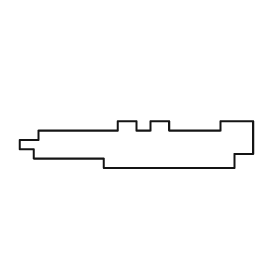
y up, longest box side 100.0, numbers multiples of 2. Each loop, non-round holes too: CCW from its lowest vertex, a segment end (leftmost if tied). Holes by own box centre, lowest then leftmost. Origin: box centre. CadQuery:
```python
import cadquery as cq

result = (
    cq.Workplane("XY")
    .moveTo(-14.0, -10.0)
    .lineTo(42.0, -10.0)
    .lineTo(42.0, -4.0)
    .lineTo(50.0, -4.0)
    .lineTo(50.0, 10.0)
    .lineTo(36.0, 10.0)
    .lineTo(36.0, 6.0)
    .lineTo(14.0, 6.0)
    .lineTo(14.0, 10.0)
    .lineTo(6.0, 10.0)
    .lineTo(6.0, 6.0)
    .lineTo(0.0, 6.0)
    .lineTo(0.0, 10.0)
    .lineTo(-8.0, 10.0)
    .lineTo(-8.0, 6.0)
    .lineTo(-42.0, 6.0)
    .lineTo(-42.0, 2.0)
    .lineTo(-50.0, 2.0)
    .lineTo(-50.0, -2.0)
    .lineTo(-44.0, -2.0)
    .lineTo(-44.0, -6.0)
    .lineTo(-14.0, -6.0)
    .close()
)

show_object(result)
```